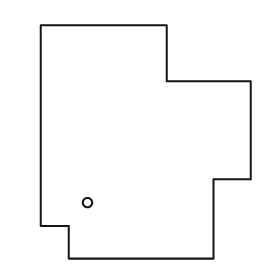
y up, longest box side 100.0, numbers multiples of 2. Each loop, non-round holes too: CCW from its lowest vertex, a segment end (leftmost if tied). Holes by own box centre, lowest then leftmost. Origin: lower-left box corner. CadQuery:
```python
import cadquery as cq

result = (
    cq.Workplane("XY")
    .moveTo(12.0, 0.0)
    .lineTo(74.0, 0.0)
    .lineTo(74.0, 34.0)
    .lineTo(90.0, 34.0)
    .lineTo(90.0, 76.0)
    .lineTo(54.0, 76.0)
    .lineTo(54.0, 100.0)
    .lineTo(0.0, 100.0)
    .lineTo(0.0, 14.0)
    .lineTo(12.0, 14.0)
    .close()
    .moveTo(20.0, 24.0)
    .circle(2.0)
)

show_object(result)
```